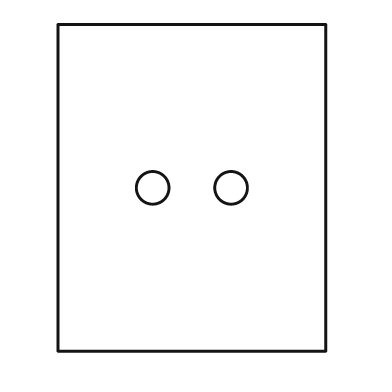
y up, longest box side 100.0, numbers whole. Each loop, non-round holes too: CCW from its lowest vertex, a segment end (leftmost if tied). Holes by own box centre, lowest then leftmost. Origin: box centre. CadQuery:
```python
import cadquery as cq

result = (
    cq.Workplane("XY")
    .moveTo(-41.0, -50.0)
    .lineTo(41.0, -50.0)
    .lineTo(41.0, 50.0)
    .lineTo(-41.0, 50.0)
    .close()
    .moveTo(-12.0, 0.0)
    .circle(5.0)
    .moveTo(12.0, 0.0)
    .circle(5.0)
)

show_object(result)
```